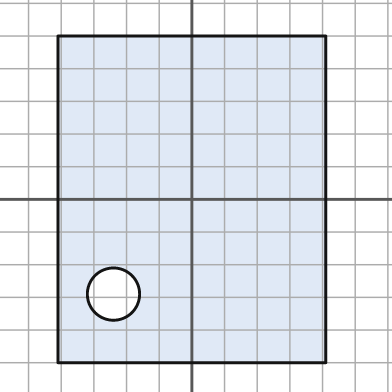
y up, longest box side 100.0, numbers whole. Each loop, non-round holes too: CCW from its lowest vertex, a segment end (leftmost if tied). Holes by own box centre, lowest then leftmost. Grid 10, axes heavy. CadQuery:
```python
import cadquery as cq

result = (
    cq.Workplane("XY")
    .moveTo(-41.0, -50.0)
    .lineTo(41.0, -50.0)
    .lineTo(41.0, 50.0)
    .lineTo(-41.0, 50.0)
    .close()
    .moveTo(-24.0, -29.0)
    .circle(8.0)
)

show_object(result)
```